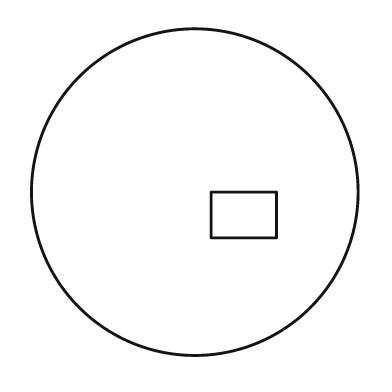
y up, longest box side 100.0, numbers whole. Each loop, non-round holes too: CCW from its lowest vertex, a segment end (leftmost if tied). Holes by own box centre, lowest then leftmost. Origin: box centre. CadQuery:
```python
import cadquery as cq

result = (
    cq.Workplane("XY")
    .moveTo(0.0, 0.0)
    .circle(50.0)
    .moveTo(5.0, -14.0)
    .lineTo(25.0, -14.0)
    .lineTo(25.0, 0.0)
    .lineTo(5.0, 0.0)
    .close()
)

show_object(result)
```